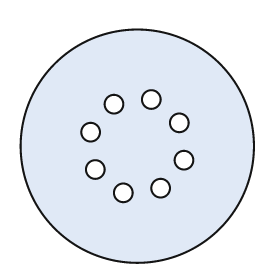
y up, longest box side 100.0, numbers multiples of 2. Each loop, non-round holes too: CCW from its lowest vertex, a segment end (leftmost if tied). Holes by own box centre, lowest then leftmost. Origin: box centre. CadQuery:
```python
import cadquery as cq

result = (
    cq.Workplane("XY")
    .moveTo(0.0, 0.0)
    .circle(50.0)
    .moveTo(-6.0, -20.0)
    .circle(4.0)
    .moveTo(10.0, -18.0)
    .circle(4.0)
    .moveTo(-18.0, -10.0)
    .circle(4.0)
    .moveTo(20.0, -6.0)
    .circle(4.0)
    .moveTo(-20.0, 6.0)
    .circle(4.0)
    .moveTo(18.0, 10.0)
    .circle(4.0)
    .moveTo(-10.0, 18.0)
    .circle(4.0)
    .moveTo(6.0, 20.0)
    .circle(4.0)
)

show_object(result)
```